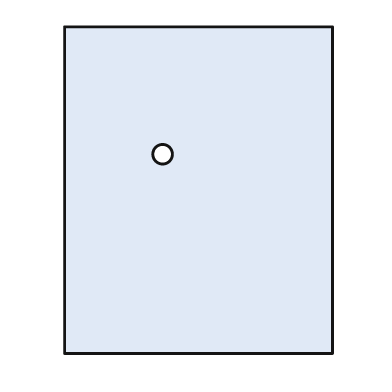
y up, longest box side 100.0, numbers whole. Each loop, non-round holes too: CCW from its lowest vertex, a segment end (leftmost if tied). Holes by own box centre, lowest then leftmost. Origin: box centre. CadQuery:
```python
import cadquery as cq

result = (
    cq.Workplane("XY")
    .moveTo(-41.0, -50.0)
    .lineTo(41.0, -50.0)
    .lineTo(41.0, 50.0)
    .lineTo(-41.0, 50.0)
    .close()
    .moveTo(-11.0, 11.0)
    .circle(3.0)
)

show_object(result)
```